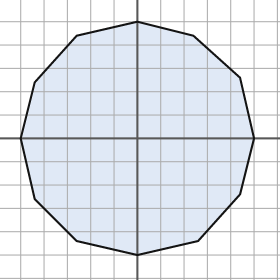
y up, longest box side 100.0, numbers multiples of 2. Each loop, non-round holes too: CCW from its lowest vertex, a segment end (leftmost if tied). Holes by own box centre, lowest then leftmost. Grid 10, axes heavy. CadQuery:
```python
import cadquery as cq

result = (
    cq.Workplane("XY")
    .moveTo(0.0, -50.0)
    .lineTo(26.0, -44.0)
    .lineTo(44.0, -24.0)
    .lineTo(50.0, 0.0)
    .lineTo(44.0, 26.0)
    .lineTo(24.0, 44.0)
    .lineTo(0.0, 50.0)
    .lineTo(-26.0, 44.0)
    .lineTo(-44.0, 24.0)
    .lineTo(-50.0, 0.0)
    .lineTo(-44.0, -26.0)
    .lineTo(-26.0, -44.0)
    .close()
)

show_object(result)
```